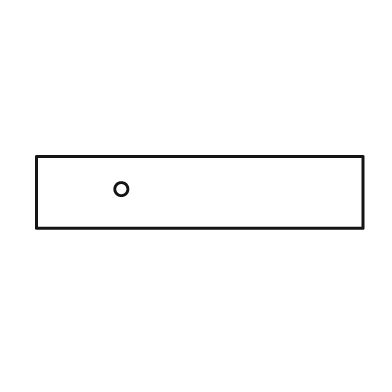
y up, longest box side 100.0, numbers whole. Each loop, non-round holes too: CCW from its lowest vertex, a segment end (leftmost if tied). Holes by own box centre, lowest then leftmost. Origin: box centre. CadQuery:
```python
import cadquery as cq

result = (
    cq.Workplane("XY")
    .moveTo(-50.0, -11.0)
    .lineTo(50.0, -11.0)
    .lineTo(50.0, 11.0)
    .lineTo(-50.0, 11.0)
    .close()
    .moveTo(-24.0, 1.0)
    .circle(2.0)
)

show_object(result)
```